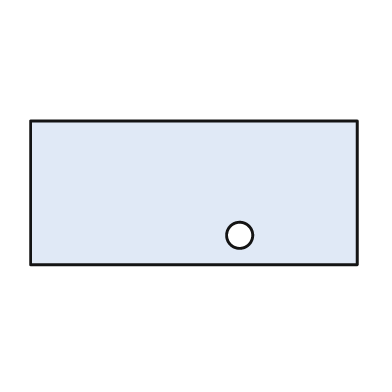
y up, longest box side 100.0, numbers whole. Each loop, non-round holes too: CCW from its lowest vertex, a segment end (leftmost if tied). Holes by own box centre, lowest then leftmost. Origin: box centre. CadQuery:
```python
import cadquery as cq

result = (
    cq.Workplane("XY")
    .moveTo(-50.0, -22.0)
    .lineTo(50.0, -22.0)
    .lineTo(50.0, 22.0)
    .lineTo(-50.0, 22.0)
    .close()
    .moveTo(14.0, -13.0)
    .circle(4.0)
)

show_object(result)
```